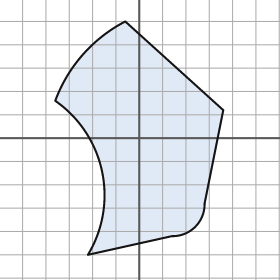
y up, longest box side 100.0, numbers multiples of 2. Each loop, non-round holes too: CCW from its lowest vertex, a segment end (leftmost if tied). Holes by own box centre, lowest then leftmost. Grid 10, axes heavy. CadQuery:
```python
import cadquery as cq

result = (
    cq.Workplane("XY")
    .moveTo(-22.0, -50.0)
    .lineTo(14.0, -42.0)
    .threePointArc((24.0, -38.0), (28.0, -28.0))
    .lineTo(36.0, 12.0)
    .lineTo(-6.0, 50.0)
    .threePointArc((-24.0, 36.0), (-36.0, 16.0))
    .threePointArc((-16.0, -14.0), (-22.0, -50.0))
    .close()
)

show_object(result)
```